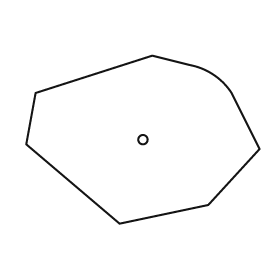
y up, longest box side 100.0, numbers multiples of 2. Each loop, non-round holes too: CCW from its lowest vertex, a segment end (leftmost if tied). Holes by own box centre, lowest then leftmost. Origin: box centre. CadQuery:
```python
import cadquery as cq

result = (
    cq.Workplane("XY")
    .moveTo(-10.0, -36.0)
    .lineTo(28.0, -28.0)
    .lineTo(50.0, -4.0)
    .lineTo(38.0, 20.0)
    .threePointArc((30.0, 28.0), (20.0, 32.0))
    .lineTo(4.0, 36.0)
    .lineTo(-46.0, 20.0)
    .lineTo(-50.0, -2.0)
    .close()
    .moveTo(0.0, 0.0)
    .circle(2.0)
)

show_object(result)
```